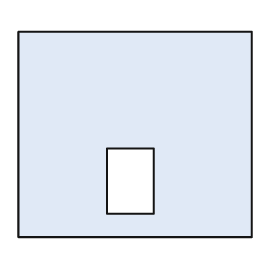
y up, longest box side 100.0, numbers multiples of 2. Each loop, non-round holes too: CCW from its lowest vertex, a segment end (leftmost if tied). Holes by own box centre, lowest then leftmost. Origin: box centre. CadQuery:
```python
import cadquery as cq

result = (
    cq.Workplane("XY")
    .moveTo(-50.0, -44.0)
    .lineTo(50.0, -44.0)
    .lineTo(50.0, 44.0)
    .lineTo(-50.0, 44.0)
    .close()
    .moveTo(-12.0, -34.0)
    .lineTo(8.0, -34.0)
    .lineTo(8.0, -6.0)
    .lineTo(-12.0, -6.0)
    .close()
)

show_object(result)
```